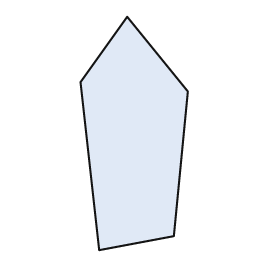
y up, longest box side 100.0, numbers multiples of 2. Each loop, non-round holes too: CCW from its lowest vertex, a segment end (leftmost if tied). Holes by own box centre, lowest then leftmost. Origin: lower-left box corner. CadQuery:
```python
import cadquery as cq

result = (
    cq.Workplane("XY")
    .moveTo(8.0, 0.0)
    .lineTo(40.0, 6.0)
    .lineTo(46.0, 68.0)
    .lineTo(20.0, 100.0)
    .lineTo(0.0, 72.0)
    .close()
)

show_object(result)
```